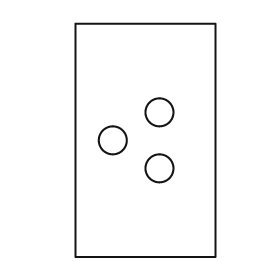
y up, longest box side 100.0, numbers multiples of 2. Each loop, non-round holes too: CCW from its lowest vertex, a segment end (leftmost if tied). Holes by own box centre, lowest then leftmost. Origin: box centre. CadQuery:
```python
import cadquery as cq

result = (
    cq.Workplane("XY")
    .moveTo(-30.0, -50.0)
    .lineTo(30.0, -50.0)
    .lineTo(30.0, 50.0)
    .lineTo(-30.0, 50.0)
    .close()
    .moveTo(6.0, -12.0)
    .circle(6.0)
    .moveTo(-14.0, 0.0)
    .circle(6.0)
    .moveTo(6.0, 12.0)
    .circle(6.0)
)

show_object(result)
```